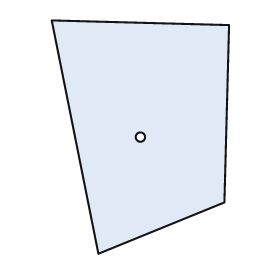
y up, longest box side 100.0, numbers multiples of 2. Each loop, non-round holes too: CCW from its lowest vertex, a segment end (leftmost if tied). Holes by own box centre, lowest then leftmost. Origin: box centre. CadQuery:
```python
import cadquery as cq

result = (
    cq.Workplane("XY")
    .moveTo(-18.0, -50.0)
    .lineTo(36.0, -28.0)
    .lineTo(38.0, 48.0)
    .lineTo(-38.0, 50.0)
    .close()
    .moveTo(0.0, 0.0)
    .circle(2.0)
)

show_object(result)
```